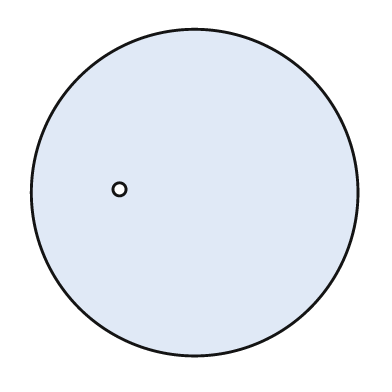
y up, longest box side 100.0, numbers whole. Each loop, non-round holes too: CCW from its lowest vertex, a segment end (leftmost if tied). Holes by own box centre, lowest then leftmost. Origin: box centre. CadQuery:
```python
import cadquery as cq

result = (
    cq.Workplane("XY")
    .moveTo(0.0, 0.0)
    .circle(50.0)
    .moveTo(-23.0, 1.0)
    .circle(2.0)
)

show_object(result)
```